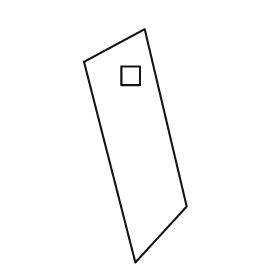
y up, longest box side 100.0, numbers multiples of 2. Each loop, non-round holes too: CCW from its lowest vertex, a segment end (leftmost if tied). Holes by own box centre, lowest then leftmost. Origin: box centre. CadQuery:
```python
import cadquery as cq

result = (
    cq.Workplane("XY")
    .moveTo(0.0, -50.0)
    .lineTo(22.0, -26.0)
    .lineTo(4.0, 50.0)
    .lineTo(-22.0, 36.0)
    .close()
    .moveTo(-6.0, 26.0)
    .lineTo(2.0, 26.0)
    .lineTo(2.0, 34.0)
    .lineTo(-6.0, 34.0)
    .close()
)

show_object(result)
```